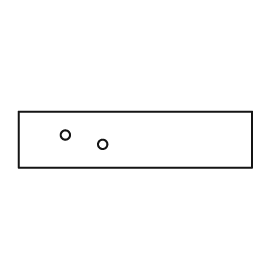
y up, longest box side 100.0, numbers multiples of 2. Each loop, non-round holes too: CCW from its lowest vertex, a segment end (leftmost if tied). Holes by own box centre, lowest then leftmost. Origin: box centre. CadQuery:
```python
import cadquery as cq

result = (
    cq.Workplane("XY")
    .moveTo(-50.0, -12.0)
    .lineTo(50.0, -12.0)
    .lineTo(50.0, 12.0)
    .lineTo(-50.0, 12.0)
    .close()
    .moveTo(-14.0, -2.0)
    .circle(2.0)
    .moveTo(-30.0, 2.0)
    .circle(2.0)
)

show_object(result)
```